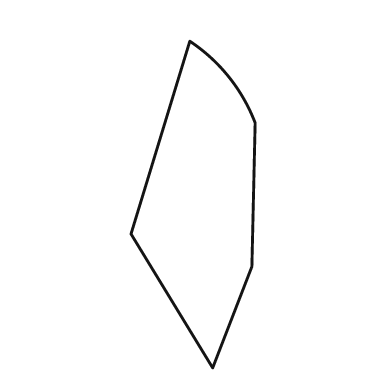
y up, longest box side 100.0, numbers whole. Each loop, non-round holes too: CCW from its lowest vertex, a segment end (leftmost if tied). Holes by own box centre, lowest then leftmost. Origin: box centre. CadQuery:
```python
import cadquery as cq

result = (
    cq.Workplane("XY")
    .moveTo(6.0, -50.0)
    .lineTo(18.0, -19.0)
    .lineTo(19.0, 25.0)
    .threePointArc((11.0, 39.0), (-1.0, 50.0))
    .lineTo(-19.0, -9.0)
    .close()
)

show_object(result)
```